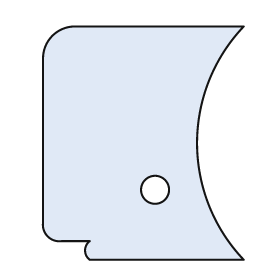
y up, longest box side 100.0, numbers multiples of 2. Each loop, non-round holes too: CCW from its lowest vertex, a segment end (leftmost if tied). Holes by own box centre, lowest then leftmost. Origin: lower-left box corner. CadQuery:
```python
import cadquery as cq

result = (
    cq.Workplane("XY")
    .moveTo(20.0, 0.0)
    .lineTo(86.0, 0.0)
    .threePointArc((66.0, 50.0), (86.0, 100.0))
    .lineTo(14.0, 100.0)
    .threePointArc((4.0, 96.0), (0.0, 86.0))
    .lineTo(0.0, 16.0)
    .threePointArc((2.0, 10.0), (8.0, 8.0))
    .lineTo(20.0, 8.0)
    .threePointArc((18.0, 4.0), (20.0, 0.0))
    .close()
    .moveTo(48.0, 30.0)
    .circle(6.0)
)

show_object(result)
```